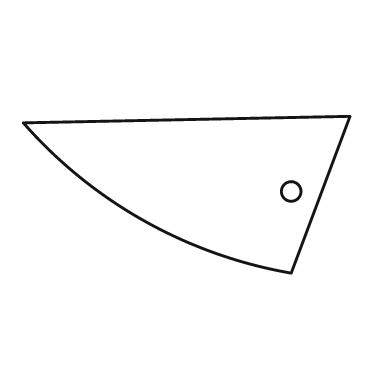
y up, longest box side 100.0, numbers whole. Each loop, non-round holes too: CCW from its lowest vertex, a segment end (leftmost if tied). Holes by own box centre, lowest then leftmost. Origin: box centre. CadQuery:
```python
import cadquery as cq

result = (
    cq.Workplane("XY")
    .moveTo(32.0, -24.0)
    .lineTo(50.0, 24.0)
    .lineTo(-50.0, 22.0)
    .threePointArc((-13.0, -8.0), (32.0, -24.0))
    .close()
    .moveTo(32.0, 1.0)
    .circle(3.0)
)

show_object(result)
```